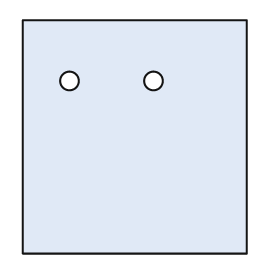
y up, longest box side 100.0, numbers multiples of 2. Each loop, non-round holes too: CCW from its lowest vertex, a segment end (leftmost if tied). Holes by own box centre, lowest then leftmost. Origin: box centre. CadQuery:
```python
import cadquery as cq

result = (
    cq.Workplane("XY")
    .moveTo(-48.0, -50.0)
    .lineTo(48.0, -50.0)
    .lineTo(48.0, 50.0)
    .lineTo(-48.0, 50.0)
    .close()
    .moveTo(-28.0, 24.0)
    .circle(4.0)
    .moveTo(8.0, 24.0)
    .circle(4.0)
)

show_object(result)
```